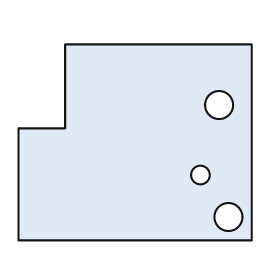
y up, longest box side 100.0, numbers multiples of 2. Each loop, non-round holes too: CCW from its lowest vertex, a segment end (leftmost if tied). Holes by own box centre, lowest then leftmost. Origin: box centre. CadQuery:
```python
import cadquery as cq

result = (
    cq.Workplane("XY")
    .moveTo(-50.0, -42.0)
    .lineTo(50.0, -42.0)
    .lineTo(50.0, 42.0)
    .lineTo(-30.0, 42.0)
    .lineTo(-30.0, 6.0)
    .lineTo(-50.0, 6.0)
    .close()
    .moveTo(40.0, -32.0)
    .circle(6.0)
    .moveTo(28.0, -14.0)
    .circle(4.0)
    .moveTo(36.0, 16.0)
    .circle(6.0)
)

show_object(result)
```